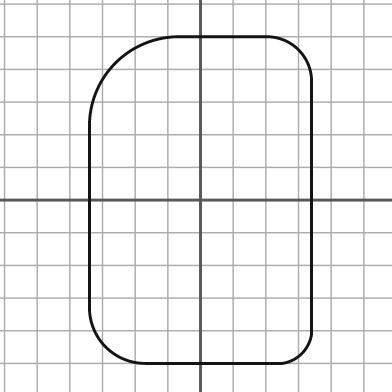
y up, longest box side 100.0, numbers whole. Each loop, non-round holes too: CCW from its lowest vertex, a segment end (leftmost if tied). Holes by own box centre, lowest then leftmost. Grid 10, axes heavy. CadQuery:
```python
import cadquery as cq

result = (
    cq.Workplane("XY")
    .moveTo(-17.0, -50.0)
    .lineTo(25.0, -50.0)
    .threePointArc((31.0, -47.0), (34.0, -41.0))
    .lineTo(34.0, 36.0)
    .threePointArc((30.0, 46.0), (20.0, 50.0))
    .lineTo(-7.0, 50.0)
    .threePointArc((-26.0, 42.0), (-34.0, 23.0))
    .lineTo(-34.0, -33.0)
    .threePointArc((-29.0, -45.0), (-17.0, -50.0))
    .close()
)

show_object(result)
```